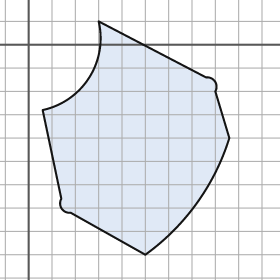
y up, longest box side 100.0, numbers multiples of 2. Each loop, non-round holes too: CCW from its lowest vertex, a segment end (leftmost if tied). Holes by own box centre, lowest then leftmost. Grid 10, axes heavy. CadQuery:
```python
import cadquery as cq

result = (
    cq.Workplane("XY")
    .moveTo(50.0, -90.0)
    .threePointArc((72.0, -68.0), (86.0, -40.0))
    .lineTo(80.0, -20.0)
    .threePointArc((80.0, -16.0), (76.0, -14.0))
    .lineTo(30.0, 10.0)
    .threePointArc((26.0, -14.0), (6.0, -28.0))
    .lineTo(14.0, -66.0)
    .threePointArc((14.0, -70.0), (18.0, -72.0))
    .close()
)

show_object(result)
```